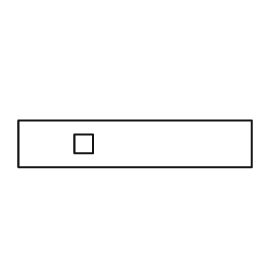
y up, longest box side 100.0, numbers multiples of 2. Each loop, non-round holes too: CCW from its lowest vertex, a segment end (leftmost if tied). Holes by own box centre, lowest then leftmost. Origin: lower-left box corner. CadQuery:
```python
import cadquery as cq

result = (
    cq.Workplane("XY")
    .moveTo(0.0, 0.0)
    .lineTo(100.0, 0.0)
    .lineTo(100.0, 20.0)
    .lineTo(0.0, 20.0)
    .close()
    .moveTo(24.0, 6.0)
    .lineTo(32.0, 6.0)
    .lineTo(32.0, 14.0)
    .lineTo(24.0, 14.0)
    .close()
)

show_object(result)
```